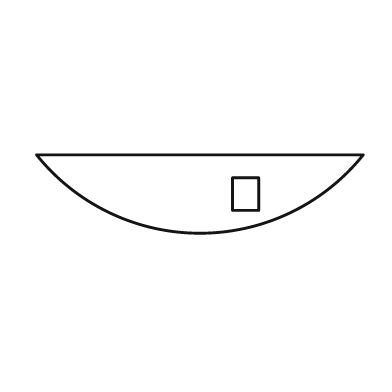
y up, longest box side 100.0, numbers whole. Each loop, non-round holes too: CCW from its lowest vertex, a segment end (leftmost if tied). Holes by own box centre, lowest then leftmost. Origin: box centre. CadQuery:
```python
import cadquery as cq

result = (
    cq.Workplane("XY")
    .moveTo(-50.0, 12.0)
    .threePointArc((0.0, -12.0), (50.0, 12.0))
    .close()
    .moveTo(10.0, -5.0)
    .lineTo(18.0, -5.0)
    .lineTo(18.0, 5.0)
    .lineTo(10.0, 5.0)
    .close()
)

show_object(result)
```